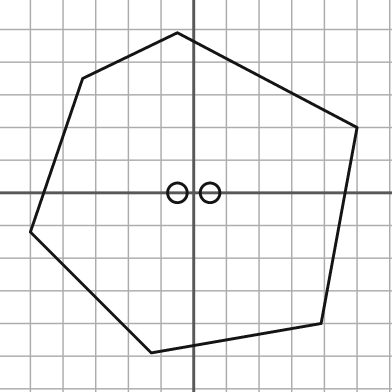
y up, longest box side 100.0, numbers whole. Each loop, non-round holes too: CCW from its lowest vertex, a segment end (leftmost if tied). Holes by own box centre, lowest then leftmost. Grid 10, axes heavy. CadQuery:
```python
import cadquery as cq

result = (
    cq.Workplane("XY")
    .moveTo(-13.0, -49.0)
    .lineTo(39.0, -40.0)
    .lineTo(50.0, 20.0)
    .lineTo(-5.0, 49.0)
    .lineTo(-34.0, 35.0)
    .lineTo(-50.0, -12.0)
    .close()
    .moveTo(-5.0, 0.0)
    .circle(3.0)
    .moveTo(5.0, 0.0)
    .circle(3.0)
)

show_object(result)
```